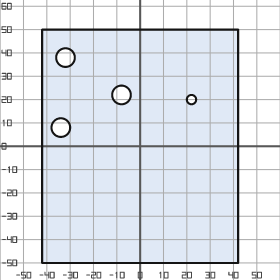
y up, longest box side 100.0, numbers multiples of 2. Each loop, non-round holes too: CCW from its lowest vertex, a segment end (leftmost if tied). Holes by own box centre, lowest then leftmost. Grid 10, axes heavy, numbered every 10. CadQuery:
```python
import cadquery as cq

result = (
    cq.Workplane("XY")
    .moveTo(-42.0, -50.0)
    .lineTo(42.0, -50.0)
    .lineTo(42.0, 50.0)
    .lineTo(-42.0, 50.0)
    .close()
    .moveTo(-34.0, 8.0)
    .circle(4.0)
    .moveTo(22.0, 20.0)
    .circle(2.0)
    .moveTo(-8.0, 22.0)
    .circle(4.0)
    .moveTo(-32.0, 38.0)
    .circle(4.0)
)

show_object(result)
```